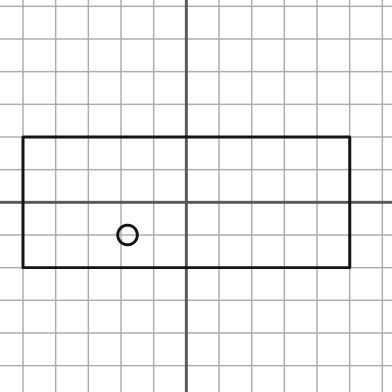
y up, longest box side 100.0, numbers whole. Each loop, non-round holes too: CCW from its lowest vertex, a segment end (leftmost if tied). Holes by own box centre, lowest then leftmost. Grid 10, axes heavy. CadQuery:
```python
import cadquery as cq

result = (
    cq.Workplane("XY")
    .moveTo(-50.0, -20.0)
    .lineTo(50.0, -20.0)
    .lineTo(50.0, 20.0)
    .lineTo(-50.0, 20.0)
    .close()
    .moveTo(-18.0, -10.0)
    .circle(3.0)
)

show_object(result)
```